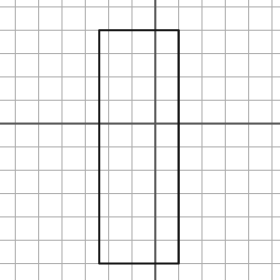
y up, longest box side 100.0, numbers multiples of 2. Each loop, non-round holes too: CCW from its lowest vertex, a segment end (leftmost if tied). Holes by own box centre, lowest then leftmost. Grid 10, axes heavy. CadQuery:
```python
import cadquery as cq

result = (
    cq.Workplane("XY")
    .moveTo(-24.0, -60.0)
    .lineTo(10.0, -60.0)
    .lineTo(10.0, 40.0)
    .lineTo(-24.0, 40.0)
    .close()
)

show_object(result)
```